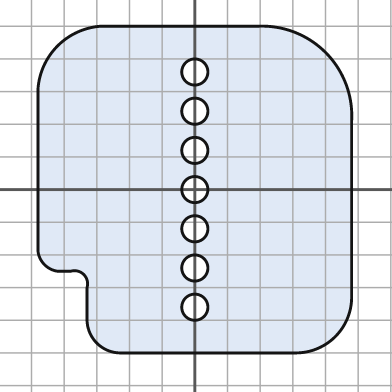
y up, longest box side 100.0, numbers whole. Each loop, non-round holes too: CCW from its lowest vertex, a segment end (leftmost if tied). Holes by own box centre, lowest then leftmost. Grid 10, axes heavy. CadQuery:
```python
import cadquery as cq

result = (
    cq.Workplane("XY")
    .moveTo(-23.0, -50.0)
    .lineTo(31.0, -50.0)
    .threePointArc((43.0, -45.0), (48.0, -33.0))
    .lineTo(48.0, 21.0)
    .threePointArc((40.0, 42.0), (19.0, 50.0))
    .lineTo(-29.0, 50.0)
    .threePointArc((-42.0, 44.0), (-48.0, 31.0))
    .lineTo(-48.0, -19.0)
    .threePointArc((-46.0, -23.0), (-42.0, -25.0))
    .lineTo(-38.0, -25.0)
    .threePointArc((-34.0, -26.0), (-33.0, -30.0))
    .lineTo(-33.0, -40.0)
    .threePointArc((-30.0, -47.0), (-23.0, -50.0))
    .close()
    .moveTo(0.0, -36.0)
    .circle(4.0)
    .moveTo(0.0, -24.0)
    .circle(4.0)
    .moveTo(0.0, -12.0)
    .circle(4.0)
    .moveTo(0.0, 0.0)
    .circle(4.0)
    .moveTo(0.0, 12.0)
    .circle(4.0)
    .moveTo(0.0, 24.0)
    .circle(4.0)
    .moveTo(0.0, 36.0)
    .circle(4.0)
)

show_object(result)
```